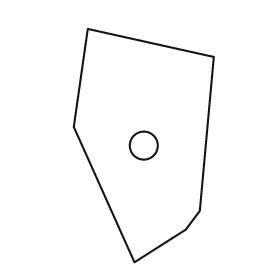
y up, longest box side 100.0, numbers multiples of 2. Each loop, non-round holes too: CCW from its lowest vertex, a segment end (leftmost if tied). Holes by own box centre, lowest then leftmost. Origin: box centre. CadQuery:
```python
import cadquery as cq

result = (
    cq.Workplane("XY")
    .moveTo(-4.0, -50.0)
    .lineTo(18.0, -36.0)
    .lineTo(24.0, -28.0)
    .lineTo(30.0, 38.0)
    .lineTo(-24.0, 50.0)
    .lineTo(-30.0, 8.0)
    .close()
    .moveTo(0.0, 0.0)
    .circle(6.0)
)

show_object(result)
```